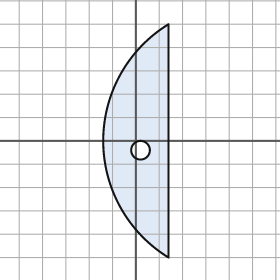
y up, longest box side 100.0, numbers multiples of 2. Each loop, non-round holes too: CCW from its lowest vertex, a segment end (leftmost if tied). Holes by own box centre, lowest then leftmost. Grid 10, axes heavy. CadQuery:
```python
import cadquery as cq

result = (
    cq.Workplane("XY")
    .moveTo(14.0, -50.0)
    .lineTo(14.0, 50.0)
    .threePointArc((-14.0, 0.0), (14.0, -50.0))
    .close()
    .moveTo(2.0, -4.0)
    .circle(4.0)
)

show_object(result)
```